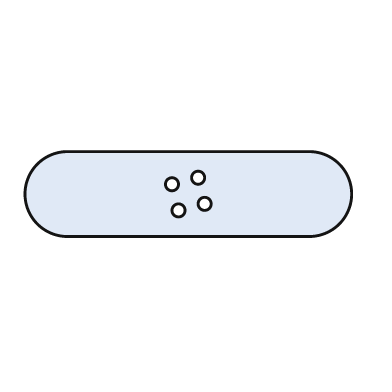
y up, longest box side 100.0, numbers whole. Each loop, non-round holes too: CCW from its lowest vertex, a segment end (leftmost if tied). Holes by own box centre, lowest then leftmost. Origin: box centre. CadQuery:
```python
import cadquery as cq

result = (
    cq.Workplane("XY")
    .moveTo(-37.0, -13.0)
    .lineTo(37.0, -13.0)
    .threePointArc((50.0, 0.0), (37.0, 13.0))
    .lineTo(-37.0, 13.0)
    .threePointArc((-50.0, 0.0), (-37.0, -13.0))
    .close()
    .moveTo(-3.0, -5.0)
    .circle(2.0)
    .moveTo(5.0, -3.0)
    .circle(2.0)
    .moveTo(-5.0, 3.0)
    .circle(2.0)
    .moveTo(3.0, 5.0)
    .circle(2.0)
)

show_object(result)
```